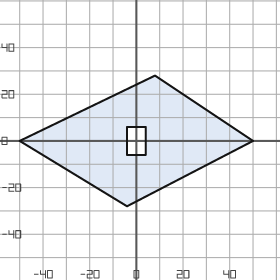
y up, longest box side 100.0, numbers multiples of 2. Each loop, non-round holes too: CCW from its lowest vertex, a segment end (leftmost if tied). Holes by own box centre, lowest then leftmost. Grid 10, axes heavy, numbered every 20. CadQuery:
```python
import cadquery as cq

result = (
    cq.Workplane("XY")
    .moveTo(-4.0, -28.0)
    .lineTo(50.0, 0.0)
    .lineTo(8.0, 28.0)
    .lineTo(-50.0, 0.0)
    .close()
    .moveTo(-4.0, -6.0)
    .lineTo(4.0, -6.0)
    .lineTo(4.0, 6.0)
    .lineTo(-4.0, 6.0)
    .close()
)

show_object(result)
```